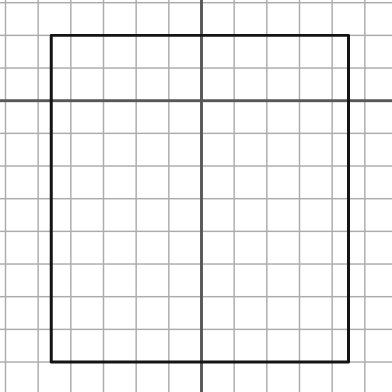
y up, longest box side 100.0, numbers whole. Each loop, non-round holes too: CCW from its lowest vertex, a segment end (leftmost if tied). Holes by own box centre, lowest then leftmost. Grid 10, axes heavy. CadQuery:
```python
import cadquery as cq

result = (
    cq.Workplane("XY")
    .moveTo(-46.0, -80.0)
    .lineTo(45.0, -80.0)
    .lineTo(45.0, 20.0)
    .lineTo(-46.0, 20.0)
    .close()
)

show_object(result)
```